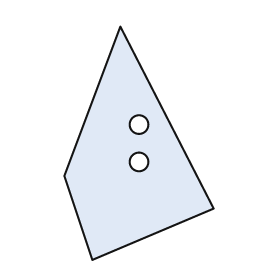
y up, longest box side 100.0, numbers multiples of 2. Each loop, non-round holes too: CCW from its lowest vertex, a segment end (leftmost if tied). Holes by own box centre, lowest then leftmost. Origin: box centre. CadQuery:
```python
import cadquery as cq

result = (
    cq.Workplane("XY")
    .moveTo(-20.0, -50.0)
    .lineTo(32.0, -28.0)
    .lineTo(-8.0, 50.0)
    .lineTo(-32.0, -14.0)
    .close()
    .moveTo(0.0, -8.0)
    .circle(4.0)
    .moveTo(0.0, 8.0)
    .circle(4.0)
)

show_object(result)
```